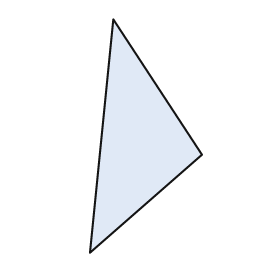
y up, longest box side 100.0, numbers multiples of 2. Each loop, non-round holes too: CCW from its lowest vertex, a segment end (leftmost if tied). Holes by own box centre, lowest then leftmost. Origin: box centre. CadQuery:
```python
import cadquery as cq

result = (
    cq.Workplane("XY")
    .moveTo(-24.0, -50.0)
    .lineTo(24.0, -8.0)
    .lineTo(-14.0, 50.0)
    .close()
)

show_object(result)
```